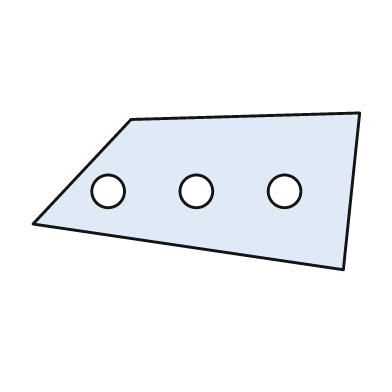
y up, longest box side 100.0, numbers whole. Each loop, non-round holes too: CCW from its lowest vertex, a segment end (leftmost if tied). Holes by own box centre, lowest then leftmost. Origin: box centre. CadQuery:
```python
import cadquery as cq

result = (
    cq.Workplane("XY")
    .moveTo(45.0, -24.0)
    .lineTo(50.0, 24.0)
    .lineTo(-20.0, 22.0)
    .lineTo(-50.0, -10.0)
    .close()
    .moveTo(-27.0, 0.0)
    .circle(5.0)
    .moveTo(0.0, 0.0)
    .circle(5.0)
    .moveTo(27.0, 0.0)
    .circle(5.0)
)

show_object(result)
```